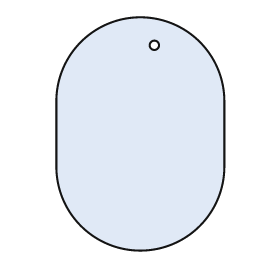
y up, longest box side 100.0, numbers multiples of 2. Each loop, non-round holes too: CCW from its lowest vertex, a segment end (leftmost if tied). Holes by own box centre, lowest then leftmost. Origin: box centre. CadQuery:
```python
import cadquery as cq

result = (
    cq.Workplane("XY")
    .moveTo(-36.0, -14.0)
    .threePointArc((0.0, -50.0), (36.0, -14.0))
    .lineTo(36.0, 14.0)
    .threePointArc((0.0, 50.0), (-36.0, 14.0))
    .close()
    .moveTo(6.0, 38.0)
    .circle(2.0)
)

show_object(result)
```